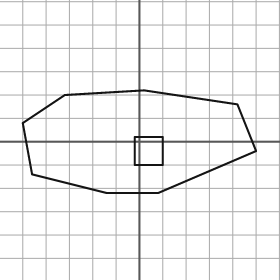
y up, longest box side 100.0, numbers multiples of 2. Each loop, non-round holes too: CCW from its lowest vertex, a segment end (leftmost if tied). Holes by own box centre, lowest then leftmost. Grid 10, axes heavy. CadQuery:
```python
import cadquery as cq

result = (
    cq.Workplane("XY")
    .moveTo(-14.0, -22.0)
    .lineTo(8.0, -22.0)
    .lineTo(50.0, -4.0)
    .lineTo(42.0, 16.0)
    .lineTo(2.0, 22.0)
    .lineTo(-32.0, 20.0)
    .lineTo(-50.0, 8.0)
    .lineTo(-46.0, -14.0)
    .close()
    .moveTo(-2.0, -10.0)
    .lineTo(10.0, -10.0)
    .lineTo(10.0, 2.0)
    .lineTo(-2.0, 2.0)
    .close()
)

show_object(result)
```